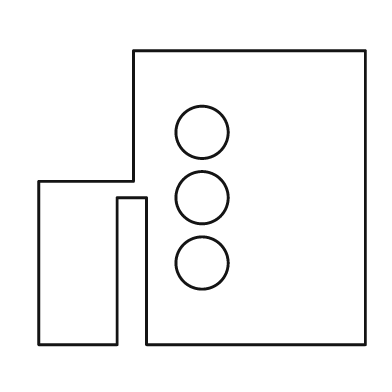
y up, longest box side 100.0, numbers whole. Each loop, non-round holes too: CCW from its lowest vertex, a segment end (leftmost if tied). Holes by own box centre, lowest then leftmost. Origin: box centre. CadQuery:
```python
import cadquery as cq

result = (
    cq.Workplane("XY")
    .moveTo(-50.0, -45.0)
    .lineTo(-26.0, -45.0)
    .lineTo(-26.0, 0.0)
    .lineTo(-17.0, 0.0)
    .lineTo(-17.0, -45.0)
    .lineTo(50.0, -45.0)
    .lineTo(50.0, 45.0)
    .lineTo(-21.0, 45.0)
    .lineTo(-21.0, 5.0)
    .lineTo(-50.0, 5.0)
    .close()
    .moveTo(0.0, -20.0)
    .circle(8.0)
    .moveTo(0.0, 0.0)
    .circle(8.0)
    .moveTo(0.0, 20.0)
    .circle(8.0)
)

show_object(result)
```